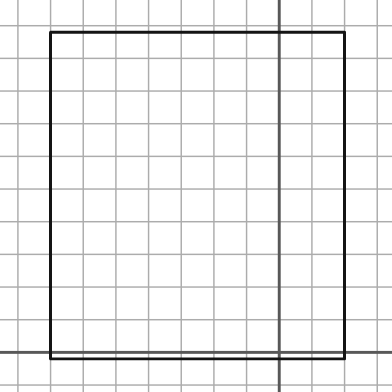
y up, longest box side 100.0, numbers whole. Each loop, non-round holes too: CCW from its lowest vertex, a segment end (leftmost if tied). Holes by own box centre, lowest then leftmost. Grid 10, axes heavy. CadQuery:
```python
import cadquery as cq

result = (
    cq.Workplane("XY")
    .moveTo(-70.0, -2.0)
    .lineTo(20.0, -2.0)
    .lineTo(20.0, 98.0)
    .lineTo(-70.0, 98.0)
    .close()
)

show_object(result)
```